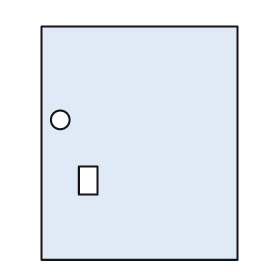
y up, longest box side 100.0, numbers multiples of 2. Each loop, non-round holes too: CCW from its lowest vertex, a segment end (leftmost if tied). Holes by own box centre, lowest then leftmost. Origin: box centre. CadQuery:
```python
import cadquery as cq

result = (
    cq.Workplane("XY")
    .moveTo(-42.0, -50.0)
    .lineTo(42.0, -50.0)
    .lineTo(42.0, 50.0)
    .lineTo(-42.0, 50.0)
    .close()
    .moveTo(-26.0, -22.0)
    .lineTo(-18.0, -22.0)
    .lineTo(-18.0, -10.0)
    .lineTo(-26.0, -10.0)
    .close()
    .moveTo(-34.0, 10.0)
    .circle(4.0)
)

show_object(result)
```